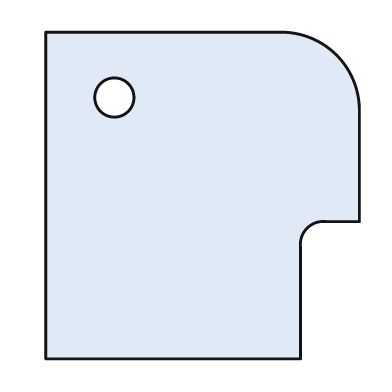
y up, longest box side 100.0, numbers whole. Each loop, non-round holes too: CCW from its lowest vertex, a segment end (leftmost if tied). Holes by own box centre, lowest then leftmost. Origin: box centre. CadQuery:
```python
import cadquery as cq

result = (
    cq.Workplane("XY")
    .moveTo(-48.0, -50.0)
    .lineTo(30.0, -50.0)
    .lineTo(30.0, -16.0)
    .threePointArc((32.0, -10.0), (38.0, -8.0))
    .lineTo(48.0, -8.0)
    .lineTo(48.0, 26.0)
    .threePointArc((41.0, 43.0), (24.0, 50.0))
    .lineTo(-48.0, 50.0)
    .close()
    .moveTo(-27.0, 30.0)
    .circle(6.0)
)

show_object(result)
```